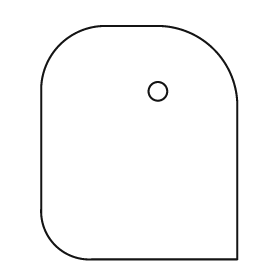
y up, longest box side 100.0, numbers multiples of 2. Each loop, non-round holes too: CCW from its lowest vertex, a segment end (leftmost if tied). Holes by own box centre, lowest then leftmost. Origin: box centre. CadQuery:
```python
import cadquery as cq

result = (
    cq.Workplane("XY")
    .moveTo(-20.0, -50.0)
    .lineTo(42.0, -50.0)
    .lineTo(42.0, 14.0)
    .threePointArc((32.0, 40.0), (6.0, 50.0))
    .lineTo(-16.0, 50.0)
    .threePointArc((-34.0, 42.0), (-42.0, 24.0))
    .lineTo(-42.0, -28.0)
    .threePointArc((-36.0, -44.0), (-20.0, -50.0))
    .close()
    .moveTo(8.0, 22.0)
    .circle(4.0)
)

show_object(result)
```